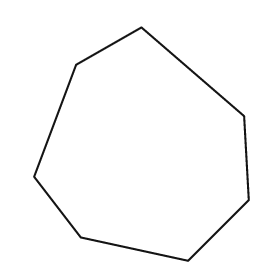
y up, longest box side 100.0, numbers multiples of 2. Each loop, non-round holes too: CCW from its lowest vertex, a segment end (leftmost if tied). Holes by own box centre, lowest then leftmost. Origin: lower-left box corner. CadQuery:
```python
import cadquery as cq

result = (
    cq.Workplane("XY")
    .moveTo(66.0, 0.0)
    .lineTo(92.0, 26.0)
    .lineTo(90.0, 62.0)
    .lineTo(46.0, 100.0)
    .lineTo(18.0, 84.0)
    .lineTo(0.0, 36.0)
    .lineTo(20.0, 10.0)
    .close()
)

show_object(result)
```